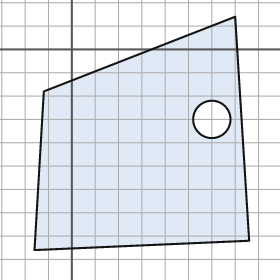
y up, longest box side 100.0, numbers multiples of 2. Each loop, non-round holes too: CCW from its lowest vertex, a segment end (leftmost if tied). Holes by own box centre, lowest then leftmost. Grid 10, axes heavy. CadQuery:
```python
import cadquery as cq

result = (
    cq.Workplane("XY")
    .moveTo(-16.0, -86.0)
    .lineTo(76.0, -82.0)
    .lineTo(70.0, 14.0)
    .lineTo(-12.0, -18.0)
    .close()
    .moveTo(60.0, -30.0)
    .circle(8.0)
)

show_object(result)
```